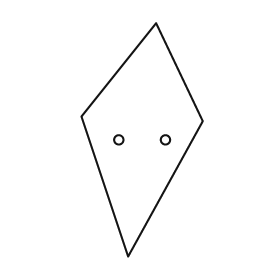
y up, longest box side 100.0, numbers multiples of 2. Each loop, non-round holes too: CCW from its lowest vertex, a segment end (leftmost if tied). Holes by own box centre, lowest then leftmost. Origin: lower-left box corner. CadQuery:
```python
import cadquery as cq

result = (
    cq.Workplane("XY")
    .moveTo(20.0, 0.0)
    .lineTo(52.0, 58.0)
    .lineTo(32.0, 100.0)
    .lineTo(0.0, 60.0)
    .close()
    .moveTo(16.0, 50.0)
    .circle(2.0)
    .moveTo(36.0, 50.0)
    .circle(2.0)
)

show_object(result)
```